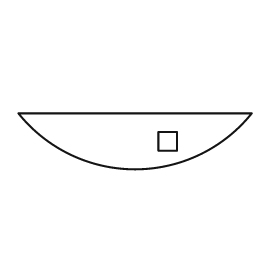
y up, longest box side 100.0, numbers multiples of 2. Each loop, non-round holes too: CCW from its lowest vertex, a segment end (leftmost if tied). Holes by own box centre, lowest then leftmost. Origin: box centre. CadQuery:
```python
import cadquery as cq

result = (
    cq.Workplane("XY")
    .moveTo(-50.0, 12.0)
    .threePointArc((0.0, -12.0), (50.0, 12.0))
    .close()
    .moveTo(10.0, -4.0)
    .lineTo(18.0, -4.0)
    .lineTo(18.0, 4.0)
    .lineTo(10.0, 4.0)
    .close()
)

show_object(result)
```